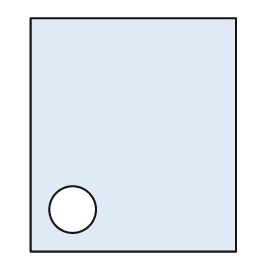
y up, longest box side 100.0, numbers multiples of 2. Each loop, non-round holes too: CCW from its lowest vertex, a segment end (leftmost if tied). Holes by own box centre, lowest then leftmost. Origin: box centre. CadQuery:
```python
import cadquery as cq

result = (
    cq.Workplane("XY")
    .moveTo(-44.0, -50.0)
    .lineTo(44.0, -50.0)
    .lineTo(44.0, 50.0)
    .lineTo(-44.0, 50.0)
    .close()
    .moveTo(-26.0, -32.0)
    .circle(10.0)
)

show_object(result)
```